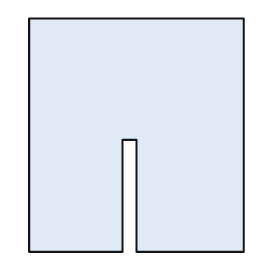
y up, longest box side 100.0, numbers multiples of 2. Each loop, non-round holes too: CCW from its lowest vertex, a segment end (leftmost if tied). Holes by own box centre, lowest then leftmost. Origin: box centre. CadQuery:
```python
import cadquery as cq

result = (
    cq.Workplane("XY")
    .moveTo(-46.0, -50.0)
    .lineTo(-6.0, -50.0)
    .lineTo(-6.0, -2.0)
    .lineTo(0.0, -2.0)
    .lineTo(0.0, -50.0)
    .lineTo(46.0, -50.0)
    .lineTo(46.0, 50.0)
    .lineTo(-46.0, 50.0)
    .close()
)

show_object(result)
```